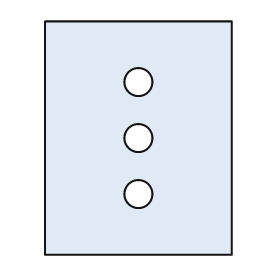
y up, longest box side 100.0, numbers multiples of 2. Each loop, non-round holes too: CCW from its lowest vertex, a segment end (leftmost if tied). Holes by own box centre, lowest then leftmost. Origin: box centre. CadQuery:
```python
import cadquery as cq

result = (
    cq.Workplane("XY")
    .moveTo(-40.0, -50.0)
    .lineTo(40.0, -50.0)
    .lineTo(40.0, 50.0)
    .lineTo(-40.0, 50.0)
    .close()
    .moveTo(0.0, -24.0)
    .circle(6.0)
    .moveTo(0.0, 0.0)
    .circle(6.0)
    .moveTo(0.0, 24.0)
    .circle(6.0)
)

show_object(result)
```